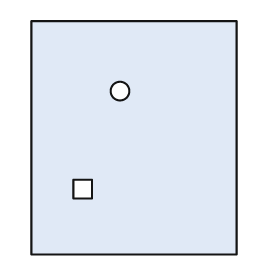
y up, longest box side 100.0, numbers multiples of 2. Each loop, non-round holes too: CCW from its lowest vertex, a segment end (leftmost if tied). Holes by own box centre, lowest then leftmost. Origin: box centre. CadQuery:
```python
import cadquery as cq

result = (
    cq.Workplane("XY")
    .moveTo(-44.0, -50.0)
    .lineTo(44.0, -50.0)
    .lineTo(44.0, 50.0)
    .lineTo(-44.0, 50.0)
    .close()
    .moveTo(-26.0, -26.0)
    .lineTo(-18.0, -26.0)
    .lineTo(-18.0, -18.0)
    .lineTo(-26.0, -18.0)
    .close()
    .moveTo(-6.0, 20.0)
    .circle(4.0)
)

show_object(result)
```